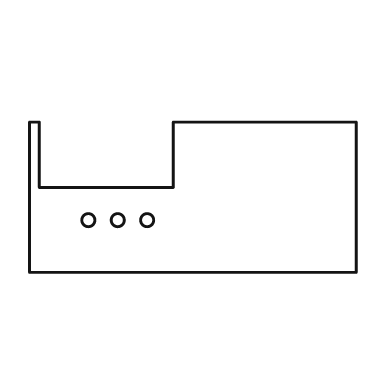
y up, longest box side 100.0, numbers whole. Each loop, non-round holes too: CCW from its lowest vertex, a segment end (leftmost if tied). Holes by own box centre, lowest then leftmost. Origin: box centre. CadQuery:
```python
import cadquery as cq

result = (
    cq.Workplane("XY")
    .moveTo(-50.0, -23.0)
    .lineTo(50.0, -23.0)
    .lineTo(50.0, 23.0)
    .lineTo(-6.0, 23.0)
    .lineTo(-6.0, 3.0)
    .lineTo(-47.0, 3.0)
    .lineTo(-47.0, 23.0)
    .lineTo(-50.0, 23.0)
    .close()
    .moveTo(-32.0, -7.0)
    .circle(2.0)
    .moveTo(-23.0, -7.0)
    .circle(2.0)
    .moveTo(-14.0, -7.0)
    .circle(2.0)
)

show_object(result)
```